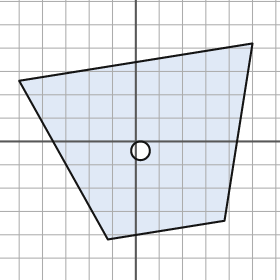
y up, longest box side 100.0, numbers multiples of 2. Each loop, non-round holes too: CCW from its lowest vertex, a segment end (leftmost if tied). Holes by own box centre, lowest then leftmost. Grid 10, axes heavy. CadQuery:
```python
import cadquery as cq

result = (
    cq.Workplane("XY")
    .moveTo(-12.0, -42.0)
    .lineTo(38.0, -34.0)
    .lineTo(50.0, 42.0)
    .lineTo(-50.0, 26.0)
    .close()
    .moveTo(2.0, -4.0)
    .circle(4.0)
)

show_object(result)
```